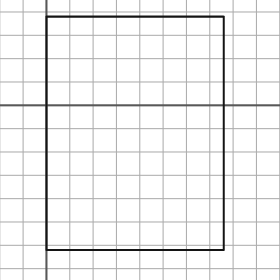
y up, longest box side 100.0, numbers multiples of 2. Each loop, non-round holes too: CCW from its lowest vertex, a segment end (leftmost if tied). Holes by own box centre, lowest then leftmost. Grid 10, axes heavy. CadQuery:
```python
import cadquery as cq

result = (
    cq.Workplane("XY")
    .moveTo(0.0, -62.0)
    .lineTo(76.0, -62.0)
    .lineTo(76.0, 38.0)
    .lineTo(0.0, 38.0)
    .close()
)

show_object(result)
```